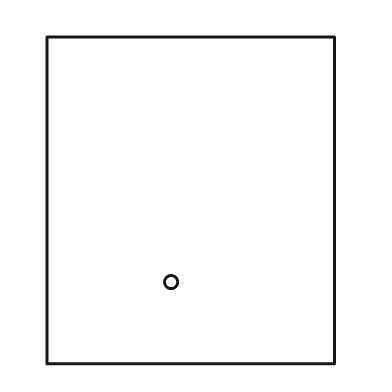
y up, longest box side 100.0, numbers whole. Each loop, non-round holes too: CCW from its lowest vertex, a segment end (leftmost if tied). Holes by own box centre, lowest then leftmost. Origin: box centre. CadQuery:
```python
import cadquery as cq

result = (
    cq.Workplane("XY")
    .moveTo(-44.0, -50.0)
    .lineTo(44.0, -50.0)
    .lineTo(44.0, 50.0)
    .lineTo(-44.0, 50.0)
    .close()
    .moveTo(-6.0, -25.0)
    .circle(2.0)
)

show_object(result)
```